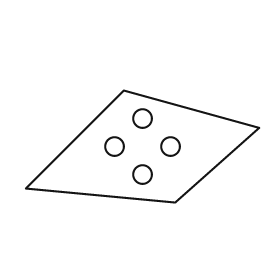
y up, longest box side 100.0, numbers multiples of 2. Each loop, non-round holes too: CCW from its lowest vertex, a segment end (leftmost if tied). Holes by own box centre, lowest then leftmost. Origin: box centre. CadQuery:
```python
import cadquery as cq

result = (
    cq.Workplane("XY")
    .moveTo(14.0, -24.0)
    .lineTo(50.0, 8.0)
    .lineTo(-8.0, 24.0)
    .lineTo(-50.0, -18.0)
    .close()
    .moveTo(0.0, -12.0)
    .circle(4.0)
    .moveTo(-12.0, 0.0)
    .circle(4.0)
    .moveTo(12.0, 0.0)
    .circle(4.0)
    .moveTo(0.0, 12.0)
    .circle(4.0)
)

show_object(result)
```